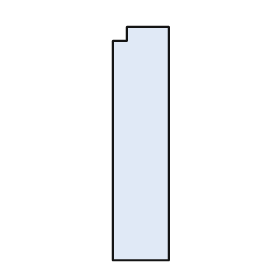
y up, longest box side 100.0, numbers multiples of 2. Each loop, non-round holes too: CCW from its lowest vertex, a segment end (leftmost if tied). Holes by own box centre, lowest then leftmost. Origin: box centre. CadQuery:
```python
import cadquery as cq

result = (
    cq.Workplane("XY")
    .moveTo(-12.0, -50.0)
    .lineTo(12.0, -50.0)
    .lineTo(12.0, 50.0)
    .lineTo(-6.0, 50.0)
    .lineTo(-6.0, 44.0)
    .lineTo(-12.0, 44.0)
    .close()
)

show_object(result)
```